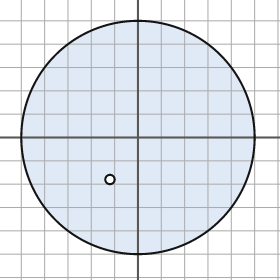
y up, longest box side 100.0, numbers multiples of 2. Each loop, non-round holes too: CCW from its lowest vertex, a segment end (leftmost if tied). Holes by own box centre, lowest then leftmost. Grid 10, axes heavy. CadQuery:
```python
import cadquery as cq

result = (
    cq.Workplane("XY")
    .moveTo(0.0, 0.0)
    .circle(50.0)
    .moveTo(-12.0, -18.0)
    .circle(2.0)
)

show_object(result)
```